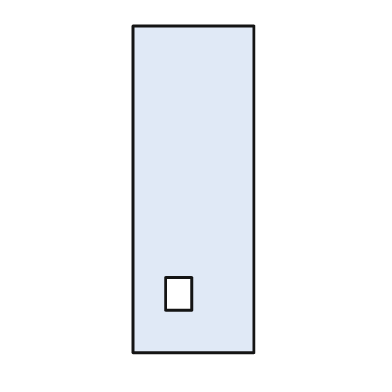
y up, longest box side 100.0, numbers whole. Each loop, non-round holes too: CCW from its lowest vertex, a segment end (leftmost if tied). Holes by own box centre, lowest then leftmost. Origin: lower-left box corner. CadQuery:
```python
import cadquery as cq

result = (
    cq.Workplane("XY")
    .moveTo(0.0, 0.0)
    .lineTo(37.0, 0.0)
    .lineTo(37.0, 100.0)
    .lineTo(0.0, 100.0)
    .close()
    .moveTo(10.0, 13.0)
    .lineTo(18.0, 13.0)
    .lineTo(18.0, 23.0)
    .lineTo(10.0, 23.0)
    .close()
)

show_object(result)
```